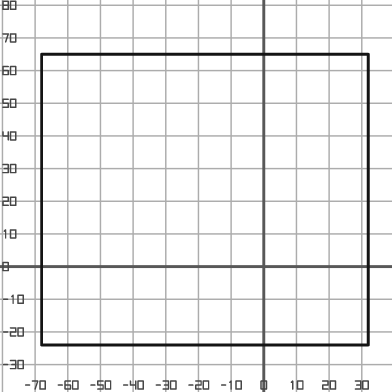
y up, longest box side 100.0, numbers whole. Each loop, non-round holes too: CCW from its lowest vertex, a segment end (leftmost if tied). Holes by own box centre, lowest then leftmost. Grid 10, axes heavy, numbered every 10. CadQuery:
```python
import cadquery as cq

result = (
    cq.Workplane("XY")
    .moveTo(-68.0, -24.0)
    .lineTo(32.0, -24.0)
    .lineTo(32.0, 65.0)
    .lineTo(-68.0, 65.0)
    .close()
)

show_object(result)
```